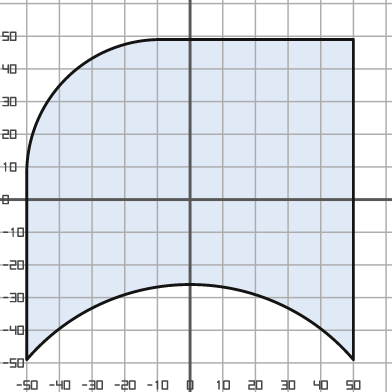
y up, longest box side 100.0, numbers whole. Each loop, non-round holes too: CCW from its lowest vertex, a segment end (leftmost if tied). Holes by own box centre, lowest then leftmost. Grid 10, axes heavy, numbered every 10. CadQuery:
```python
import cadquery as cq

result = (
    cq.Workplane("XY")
    .moveTo(-50.0, -49.0)
    .threePointArc((0.0, -26.0), (50.0, -49.0))
    .lineTo(50.0, 49.0)
    .lineTo(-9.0, 49.0)
    .threePointArc((-38.0, 37.0), (-50.0, 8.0))
    .close()
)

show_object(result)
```